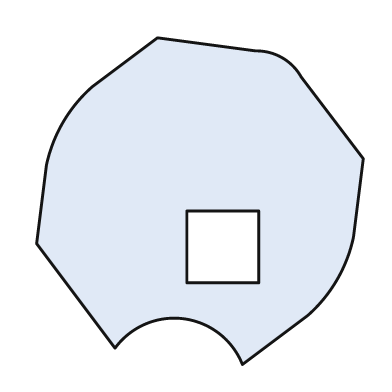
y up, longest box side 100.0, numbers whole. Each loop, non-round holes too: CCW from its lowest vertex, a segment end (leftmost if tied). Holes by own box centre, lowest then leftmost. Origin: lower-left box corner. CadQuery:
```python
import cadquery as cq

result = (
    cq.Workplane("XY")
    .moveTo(63.0, 0.0)
    .lineTo(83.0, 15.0)
    .threePointArc((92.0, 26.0), (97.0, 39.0))
    .lineTo(100.0, 63.0)
    .lineTo(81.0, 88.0)
    .threePointArc((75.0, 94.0), (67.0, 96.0))
    .lineTo(37.0, 100.0)
    .lineTo(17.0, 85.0)
    .threePointArc((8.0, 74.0), (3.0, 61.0))
    .lineTo(0.0, 37.0)
    .lineTo(24.0, 5.0)
    .threePointArc((45.0, 14.0), (63.0, 0.0))
    .close()
    .moveTo(46.0, 25.0)
    .lineTo(68.0, 25.0)
    .lineTo(68.0, 47.0)
    .lineTo(46.0, 47.0)
    .close()
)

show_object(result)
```